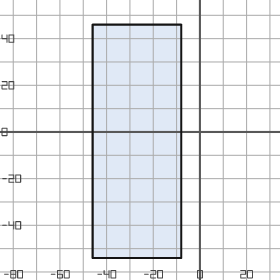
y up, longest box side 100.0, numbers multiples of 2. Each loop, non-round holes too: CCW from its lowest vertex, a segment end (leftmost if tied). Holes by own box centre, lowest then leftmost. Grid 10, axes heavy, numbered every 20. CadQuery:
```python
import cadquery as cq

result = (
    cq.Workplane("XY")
    .moveTo(-46.0, -54.0)
    .lineTo(-8.0, -54.0)
    .lineTo(-8.0, 46.0)
    .lineTo(-46.0, 46.0)
    .close()
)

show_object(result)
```